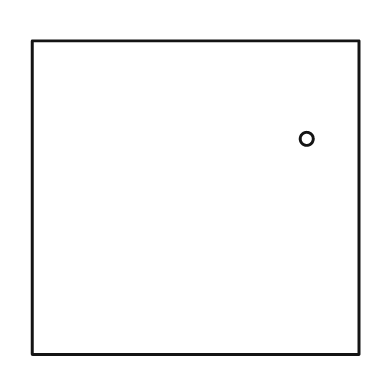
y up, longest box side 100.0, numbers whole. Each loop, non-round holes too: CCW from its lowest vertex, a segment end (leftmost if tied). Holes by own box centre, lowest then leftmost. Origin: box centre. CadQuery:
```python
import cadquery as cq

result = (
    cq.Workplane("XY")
    .moveTo(-50.0, -48.0)
    .lineTo(50.0, -48.0)
    .lineTo(50.0, 48.0)
    .lineTo(-50.0, 48.0)
    .close()
    .moveTo(34.0, 18.0)
    .circle(2.0)
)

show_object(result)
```